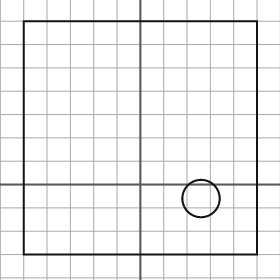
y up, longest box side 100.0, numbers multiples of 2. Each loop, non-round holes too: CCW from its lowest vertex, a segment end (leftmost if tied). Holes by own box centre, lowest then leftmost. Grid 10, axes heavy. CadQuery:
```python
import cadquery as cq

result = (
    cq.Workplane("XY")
    .moveTo(-50.0, -30.0)
    .lineTo(50.0, -30.0)
    .lineTo(50.0, 70.0)
    .lineTo(-50.0, 70.0)
    .close()
    .moveTo(26.0, -6.0)
    .circle(8.0)
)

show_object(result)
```